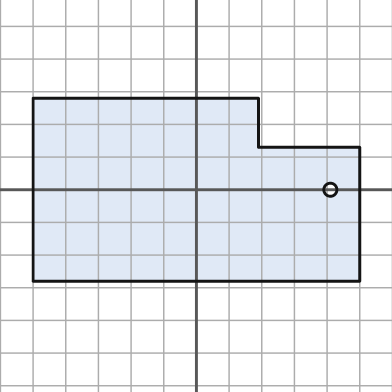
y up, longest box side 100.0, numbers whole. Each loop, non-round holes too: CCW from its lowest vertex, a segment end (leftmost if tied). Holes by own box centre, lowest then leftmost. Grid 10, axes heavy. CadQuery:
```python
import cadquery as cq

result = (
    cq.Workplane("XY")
    .moveTo(-50.0, -28.0)
    .lineTo(50.0, -28.0)
    .lineTo(50.0, 13.0)
    .lineTo(19.0, 13.0)
    .lineTo(19.0, 28.0)
    .lineTo(-50.0, 28.0)
    .close()
    .moveTo(41.0, 0.0)
    .circle(2.0)
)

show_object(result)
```